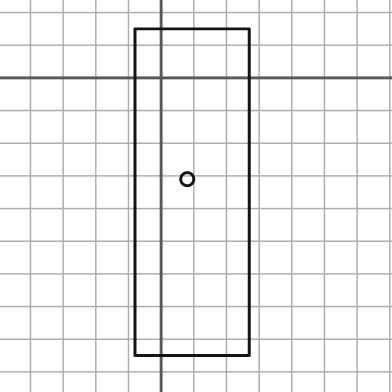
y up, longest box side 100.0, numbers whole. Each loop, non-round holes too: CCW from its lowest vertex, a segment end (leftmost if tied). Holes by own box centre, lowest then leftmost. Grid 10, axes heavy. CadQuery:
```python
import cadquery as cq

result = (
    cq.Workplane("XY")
    .moveTo(-8.0, -85.0)
    .lineTo(27.0, -85.0)
    .lineTo(27.0, 15.0)
    .lineTo(-8.0, 15.0)
    .close()
    .moveTo(8.0, -31.0)
    .circle(2.0)
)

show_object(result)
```